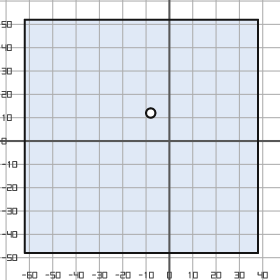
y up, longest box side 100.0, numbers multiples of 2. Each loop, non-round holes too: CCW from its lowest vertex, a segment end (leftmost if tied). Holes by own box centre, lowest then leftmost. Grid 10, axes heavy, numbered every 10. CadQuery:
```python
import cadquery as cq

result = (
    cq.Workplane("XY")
    .moveTo(-62.0, -48.0)
    .lineTo(38.0, -48.0)
    .lineTo(38.0, 52.0)
    .lineTo(-62.0, 52.0)
    .close()
    .moveTo(-8.0, 12.0)
    .circle(2.0)
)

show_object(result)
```